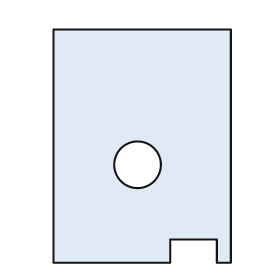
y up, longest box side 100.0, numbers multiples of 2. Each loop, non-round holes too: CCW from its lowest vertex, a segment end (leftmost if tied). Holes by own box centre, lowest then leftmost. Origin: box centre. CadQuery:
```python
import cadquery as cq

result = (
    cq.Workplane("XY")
    .moveTo(-38.0, -50.0)
    .lineTo(12.0, -50.0)
    .lineTo(12.0, -40.0)
    .lineTo(32.0, -40.0)
    .lineTo(32.0, -50.0)
    .lineTo(38.0, -50.0)
    .lineTo(38.0, 50.0)
    .lineTo(-38.0, 50.0)
    .close()
    .moveTo(-2.0, -8.0)
    .circle(10.0)
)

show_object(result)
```